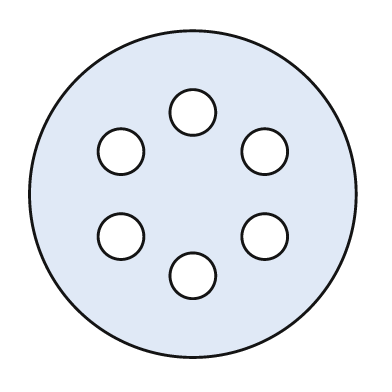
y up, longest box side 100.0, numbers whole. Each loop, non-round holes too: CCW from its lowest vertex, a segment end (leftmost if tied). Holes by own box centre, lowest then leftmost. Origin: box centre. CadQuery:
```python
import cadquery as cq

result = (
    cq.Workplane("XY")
    .moveTo(0.0, 0.0)
    .circle(50.0)
    .moveTo(0.0, -25.0)
    .circle(7.0)
    .moveTo(-22.0, -13.0)
    .circle(7.0)
    .moveTo(22.0, -13.0)
    .circle(7.0)
    .moveTo(-22.0, 13.0)
    .circle(7.0)
    .moveTo(22.0, 13.0)
    .circle(7.0)
    .moveTo(0.0, 25.0)
    .circle(7.0)
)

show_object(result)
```